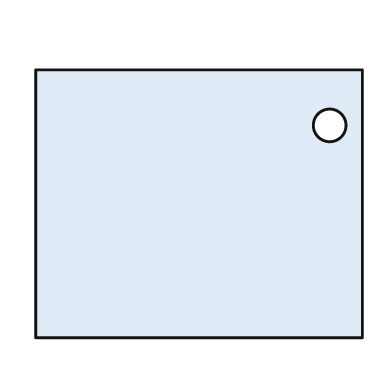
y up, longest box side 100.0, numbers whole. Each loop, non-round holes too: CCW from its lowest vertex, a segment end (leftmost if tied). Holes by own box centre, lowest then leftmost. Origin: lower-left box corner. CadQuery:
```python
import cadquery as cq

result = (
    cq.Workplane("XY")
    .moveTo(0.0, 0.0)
    .lineTo(100.0, 0.0)
    .lineTo(100.0, 82.0)
    .lineTo(0.0, 82.0)
    .close()
    .moveTo(90.0, 65.0)
    .circle(5.0)
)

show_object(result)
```